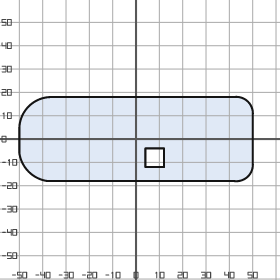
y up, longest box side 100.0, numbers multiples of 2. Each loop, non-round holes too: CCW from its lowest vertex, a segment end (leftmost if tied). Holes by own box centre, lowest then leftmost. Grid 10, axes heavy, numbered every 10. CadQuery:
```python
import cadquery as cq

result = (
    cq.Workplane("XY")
    .moveTo(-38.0, -18.0)
    .lineTo(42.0, -18.0)
    .threePointArc((48.0, -16.0), (50.0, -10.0))
    .lineTo(50.0, 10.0)
    .threePointArc((48.0, 16.0), (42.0, 18.0))
    .lineTo(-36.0, 18.0)
    .threePointArc((-46.0, 14.0), (-50.0, 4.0))
    .lineTo(-50.0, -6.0)
    .threePointArc((-46.0, -14.0), (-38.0, -18.0))
    .close()
    .moveTo(4.0, -12.0)
    .lineTo(12.0, -12.0)
    .lineTo(12.0, -4.0)
    .lineTo(4.0, -4.0)
    .close()
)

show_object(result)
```